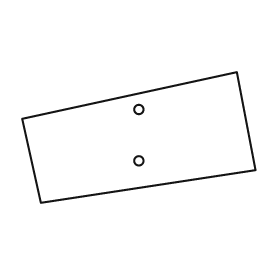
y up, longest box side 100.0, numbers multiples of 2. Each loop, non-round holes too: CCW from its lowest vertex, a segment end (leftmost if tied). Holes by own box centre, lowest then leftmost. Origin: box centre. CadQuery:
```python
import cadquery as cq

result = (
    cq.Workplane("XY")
    .moveTo(-42.0, -28.0)
    .lineTo(50.0, -14.0)
    .lineTo(42.0, 28.0)
    .lineTo(-50.0, 8.0)
    .close()
    .moveTo(0.0, -10.0)
    .circle(2.0)
    .moveTo(0.0, 12.0)
    .circle(2.0)
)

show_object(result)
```